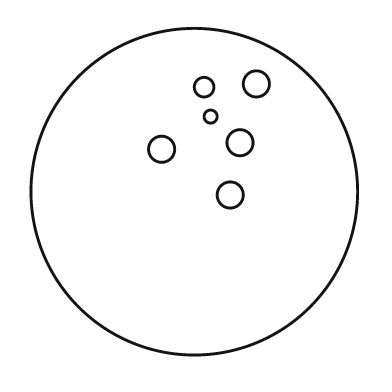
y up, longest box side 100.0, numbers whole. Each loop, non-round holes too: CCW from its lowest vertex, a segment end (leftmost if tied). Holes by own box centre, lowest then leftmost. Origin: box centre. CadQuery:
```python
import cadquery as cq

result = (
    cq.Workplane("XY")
    .moveTo(0.0, 0.0)
    .circle(50.0)
    .moveTo(11.0, -1.0)
    .circle(4.0)
    .moveTo(-10.0, 13.0)
    .circle(4.0)
    .moveTo(14.0, 15.0)
    .circle(4.0)
    .moveTo(5.0, 23.0)
    .circle(2.0)
    .moveTo(3.0, 32.0)
    .circle(3.0)
    .moveTo(19.0, 33.0)
    .circle(4.0)
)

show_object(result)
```